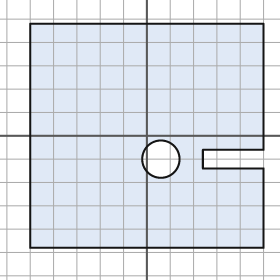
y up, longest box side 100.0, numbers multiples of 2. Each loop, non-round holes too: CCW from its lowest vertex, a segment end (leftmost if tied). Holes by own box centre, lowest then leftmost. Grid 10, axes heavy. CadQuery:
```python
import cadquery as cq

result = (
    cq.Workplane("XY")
    .moveTo(-50.0, -48.0)
    .lineTo(50.0, -48.0)
    .lineTo(50.0, -14.0)
    .lineTo(24.0, -14.0)
    .lineTo(24.0, -6.0)
    .lineTo(50.0, -6.0)
    .lineTo(50.0, 48.0)
    .lineTo(-50.0, 48.0)
    .close()
    .moveTo(6.0, -10.0)
    .circle(8.0)
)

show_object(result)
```